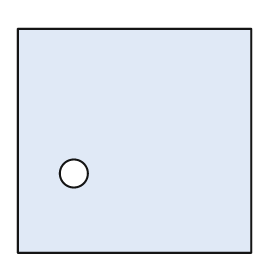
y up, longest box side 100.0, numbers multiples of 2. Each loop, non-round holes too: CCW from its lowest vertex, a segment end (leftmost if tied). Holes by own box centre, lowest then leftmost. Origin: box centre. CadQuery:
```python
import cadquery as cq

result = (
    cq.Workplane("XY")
    .moveTo(-50.0, -48.0)
    .lineTo(50.0, -48.0)
    .lineTo(50.0, 48.0)
    .lineTo(-50.0, 48.0)
    .close()
    .moveTo(-26.0, -14.0)
    .circle(6.0)
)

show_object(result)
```